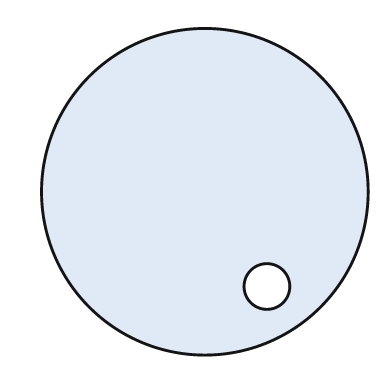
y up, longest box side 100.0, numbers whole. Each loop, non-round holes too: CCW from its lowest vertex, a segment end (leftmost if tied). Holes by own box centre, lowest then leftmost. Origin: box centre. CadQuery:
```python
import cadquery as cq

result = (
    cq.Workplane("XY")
    .moveTo(0.0, 0.0)
    .circle(50.0)
    .moveTo(19.0, -29.0)
    .circle(7.0)
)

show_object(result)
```